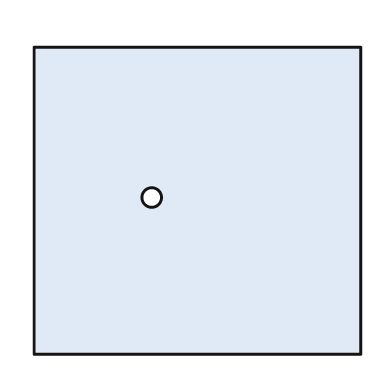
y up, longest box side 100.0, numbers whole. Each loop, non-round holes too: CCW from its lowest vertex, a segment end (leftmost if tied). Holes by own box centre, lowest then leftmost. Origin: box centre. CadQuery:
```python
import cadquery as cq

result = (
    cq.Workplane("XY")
    .moveTo(-50.0, -47.0)
    .lineTo(50.0, -47.0)
    .lineTo(50.0, 47.0)
    .lineTo(-50.0, 47.0)
    .close()
    .moveTo(-14.0, 1.0)
    .circle(3.0)
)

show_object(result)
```